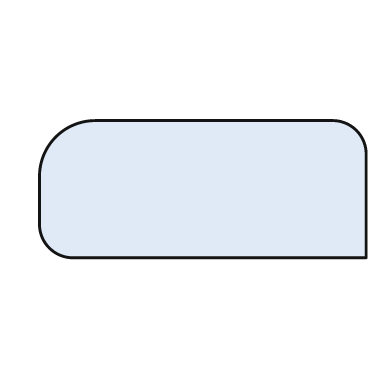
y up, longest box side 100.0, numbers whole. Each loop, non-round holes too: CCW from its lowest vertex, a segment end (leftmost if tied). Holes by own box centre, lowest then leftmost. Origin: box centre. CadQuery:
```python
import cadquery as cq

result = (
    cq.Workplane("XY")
    .moveTo(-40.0, -21.0)
    .lineTo(50.0, -21.0)
    .lineTo(50.0, 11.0)
    .threePointArc((47.0, 18.0), (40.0, 21.0))
    .lineTo(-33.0, 21.0)
    .threePointArc((-45.0, 16.0), (-50.0, 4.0))
    .lineTo(-50.0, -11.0)
    .threePointArc((-47.0, -18.0), (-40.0, -21.0))
    .close()
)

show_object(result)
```